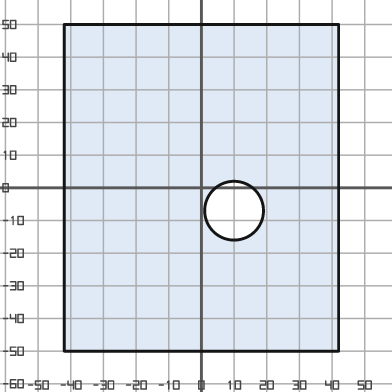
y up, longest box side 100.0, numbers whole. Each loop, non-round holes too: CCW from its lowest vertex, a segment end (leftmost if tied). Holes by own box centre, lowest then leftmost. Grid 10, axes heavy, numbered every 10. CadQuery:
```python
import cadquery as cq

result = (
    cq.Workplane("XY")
    .moveTo(-42.0, -50.0)
    .lineTo(42.0, -50.0)
    .lineTo(42.0, 50.0)
    .lineTo(-42.0, 50.0)
    .close()
    .moveTo(10.0, -7.0)
    .circle(9.0)
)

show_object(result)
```